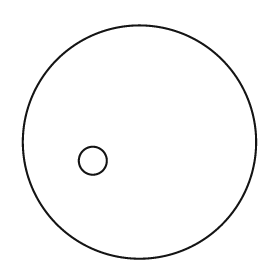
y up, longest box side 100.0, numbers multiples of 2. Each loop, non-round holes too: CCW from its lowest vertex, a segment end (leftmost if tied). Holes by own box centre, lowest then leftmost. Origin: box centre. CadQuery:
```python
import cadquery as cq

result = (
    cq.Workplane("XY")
    .moveTo(0.0, 0.0)
    .circle(50.0)
    .moveTo(-20.0, -8.0)
    .circle(6.0)
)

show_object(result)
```